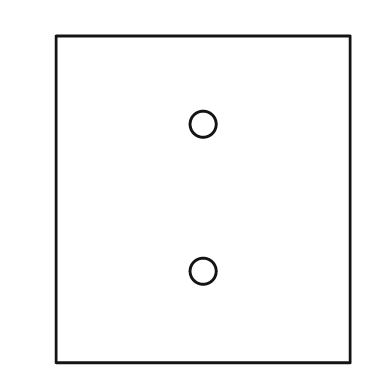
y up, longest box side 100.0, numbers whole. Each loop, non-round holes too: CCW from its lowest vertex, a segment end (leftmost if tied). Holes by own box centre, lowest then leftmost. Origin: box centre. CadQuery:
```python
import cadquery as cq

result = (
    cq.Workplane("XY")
    .moveTo(-45.0, -50.0)
    .lineTo(45.0, -50.0)
    .lineTo(45.0, 50.0)
    .lineTo(-45.0, 50.0)
    .close()
    .moveTo(0.0, -22.0)
    .circle(4.0)
    .moveTo(0.0, 23.0)
    .circle(4.0)
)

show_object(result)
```